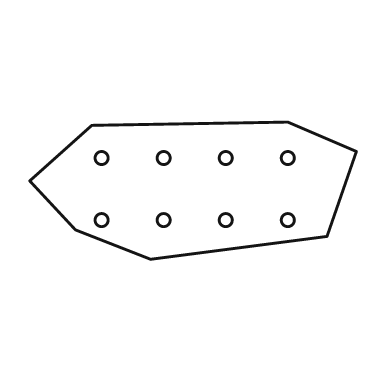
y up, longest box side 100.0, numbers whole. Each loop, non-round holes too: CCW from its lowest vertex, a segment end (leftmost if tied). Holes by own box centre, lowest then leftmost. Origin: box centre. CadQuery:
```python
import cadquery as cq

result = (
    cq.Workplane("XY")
    .moveTo(-13.0, -21.0)
    .lineTo(41.0, -14.0)
    .lineTo(50.0, 12.0)
    .lineTo(29.0, 21.0)
    .lineTo(-31.0, 20.0)
    .lineTo(-50.0, 3.0)
    .lineTo(-36.0, -12.0)
    .close()
    .moveTo(-28.0, -9.0)
    .circle(2.0)
    .moveTo(-9.0, -9.0)
    .circle(2.0)
    .moveTo(10.0, -9.0)
    .circle(2.0)
    .moveTo(29.0, -9.0)
    .circle(2.0)
    .moveTo(-28.0, 10.0)
    .circle(2.0)
    .moveTo(-9.0, 10.0)
    .circle(2.0)
    .moveTo(10.0, 10.0)
    .circle(2.0)
    .moveTo(29.0, 10.0)
    .circle(2.0)
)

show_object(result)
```